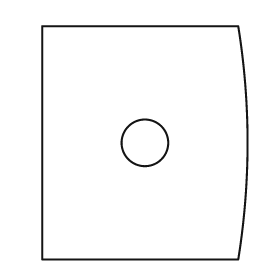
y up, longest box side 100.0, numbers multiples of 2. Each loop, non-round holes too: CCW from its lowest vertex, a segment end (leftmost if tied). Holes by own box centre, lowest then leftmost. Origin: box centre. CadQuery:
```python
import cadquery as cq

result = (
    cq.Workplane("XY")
    .moveTo(-44.0, -50.0)
    .lineTo(40.0, -50.0)
    .threePointArc((44.0, 0.0), (40.0, 50.0))
    .lineTo(-44.0, 50.0)
    .close()
    .moveTo(0.0, 0.0)
    .circle(10.0)
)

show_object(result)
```